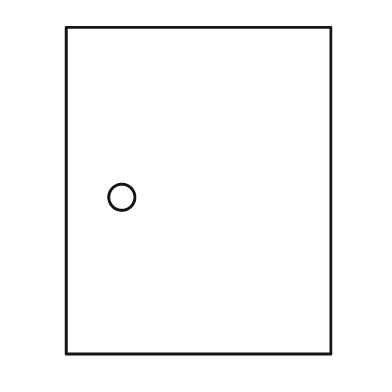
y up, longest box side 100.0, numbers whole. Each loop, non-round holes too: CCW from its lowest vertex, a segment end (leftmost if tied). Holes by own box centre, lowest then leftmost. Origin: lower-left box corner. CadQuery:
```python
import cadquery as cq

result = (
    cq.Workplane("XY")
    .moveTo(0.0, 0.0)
    .lineTo(81.0, 0.0)
    .lineTo(81.0, 100.0)
    .lineTo(0.0, 100.0)
    .close()
    .moveTo(17.0, 48.0)
    .circle(4.0)
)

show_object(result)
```